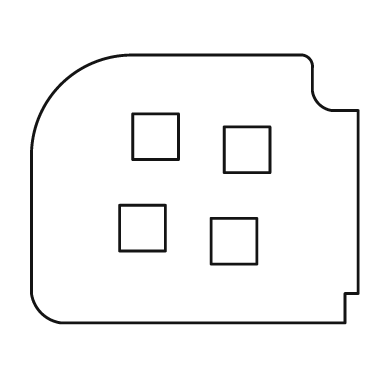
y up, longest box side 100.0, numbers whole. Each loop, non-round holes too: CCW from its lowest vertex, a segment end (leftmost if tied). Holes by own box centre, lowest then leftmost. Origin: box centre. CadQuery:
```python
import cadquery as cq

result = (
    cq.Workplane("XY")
    .moveTo(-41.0, -41.0)
    .lineTo(46.0, -41.0)
    .lineTo(46.0, -32.0)
    .lineTo(50.0, -32.0)
    .lineTo(50.0, 24.0)
    .lineTo(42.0, 24.0)
    .threePointArc((38.0, 26.0), (36.0, 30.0))
    .lineTo(36.0, 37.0)
    .threePointArc((35.0, 40.0), (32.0, 41.0))
    .lineTo(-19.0, 41.0)
    .threePointArc((-41.0, 32.0), (-50.0, 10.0))
    .lineTo(-50.0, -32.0)
    .threePointArc((-47.0, -38.0), (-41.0, -41.0))
    .close()
    .moveTo(5.0, -23.0)
    .lineTo(19.0, -23.0)
    .lineTo(19.0, -9.0)
    .lineTo(5.0, -9.0)
    .close()
    .moveTo(-23.0, -19.0)
    .lineTo(-9.0, -19.0)
    .lineTo(-9.0, -5.0)
    .lineTo(-23.0, -5.0)
    .close()
    .moveTo(9.0, 5.0)
    .lineTo(23.0, 5.0)
    .lineTo(23.0, 19.0)
    .lineTo(9.0, 19.0)
    .close()
    .moveTo(-19.0, 9.0)
    .lineTo(-5.0, 9.0)
    .lineTo(-5.0, 23.0)
    .lineTo(-19.0, 23.0)
    .close()
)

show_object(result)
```